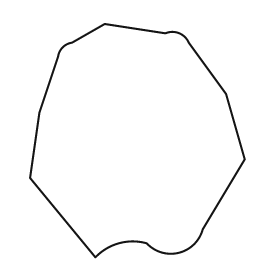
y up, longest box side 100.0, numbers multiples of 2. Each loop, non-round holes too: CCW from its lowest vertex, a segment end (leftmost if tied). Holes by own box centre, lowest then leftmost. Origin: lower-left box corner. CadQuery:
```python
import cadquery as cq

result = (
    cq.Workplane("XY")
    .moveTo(28.0, 0.0)
    .threePointArc((38.0, 6.0), (50.0, 6.0))
    .threePointArc((64.0, 2.0), (74.0, 12.0))
    .lineTo(92.0, 42.0)
    .lineTo(84.0, 70.0)
    .lineTo(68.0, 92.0)
    .threePointArc((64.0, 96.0), (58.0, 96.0))
    .lineTo(32.0, 100.0)
    .lineTo(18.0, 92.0)
    .threePointArc((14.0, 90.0), (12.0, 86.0))
    .lineTo(4.0, 62.0)
    .lineTo(0.0, 34.0)
    .close()
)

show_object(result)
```